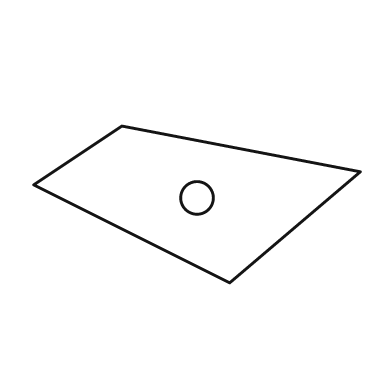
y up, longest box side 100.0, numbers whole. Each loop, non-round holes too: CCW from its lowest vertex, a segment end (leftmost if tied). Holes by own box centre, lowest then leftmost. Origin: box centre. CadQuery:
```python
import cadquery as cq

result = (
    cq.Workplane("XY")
    .moveTo(10.0, -24.0)
    .lineTo(50.0, 10.0)
    .lineTo(-23.0, 24.0)
    .lineTo(-50.0, 6.0)
    .close()
    .moveTo(0.0, 2.0)
    .circle(5.0)
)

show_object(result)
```